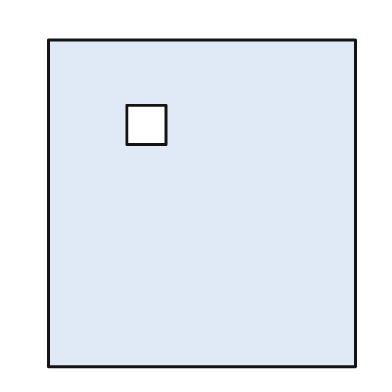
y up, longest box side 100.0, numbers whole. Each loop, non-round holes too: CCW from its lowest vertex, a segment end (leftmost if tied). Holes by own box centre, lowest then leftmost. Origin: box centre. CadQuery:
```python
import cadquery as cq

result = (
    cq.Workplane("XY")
    .moveTo(-47.0, -50.0)
    .lineTo(47.0, -50.0)
    .lineTo(47.0, 50.0)
    .lineTo(-47.0, 50.0)
    .close()
    .moveTo(-23.0, 18.0)
    .lineTo(-11.0, 18.0)
    .lineTo(-11.0, 30.0)
    .lineTo(-23.0, 30.0)
    .close()
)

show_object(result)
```